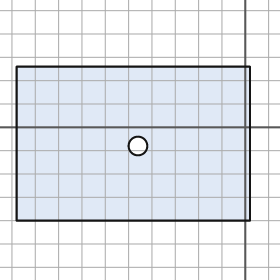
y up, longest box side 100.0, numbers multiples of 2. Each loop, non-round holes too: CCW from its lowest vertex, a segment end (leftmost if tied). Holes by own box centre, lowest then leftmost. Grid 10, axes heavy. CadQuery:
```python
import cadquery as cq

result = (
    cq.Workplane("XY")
    .moveTo(-98.0, -40.0)
    .lineTo(2.0, -40.0)
    .lineTo(2.0, 26.0)
    .lineTo(-98.0, 26.0)
    .close()
    .moveTo(-46.0, -8.0)
    .circle(4.0)
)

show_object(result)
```